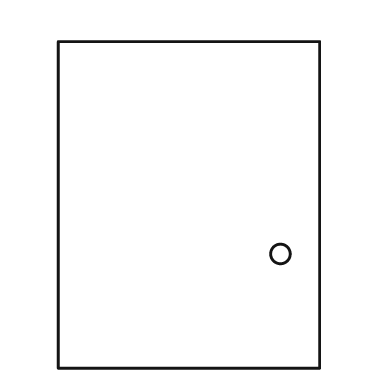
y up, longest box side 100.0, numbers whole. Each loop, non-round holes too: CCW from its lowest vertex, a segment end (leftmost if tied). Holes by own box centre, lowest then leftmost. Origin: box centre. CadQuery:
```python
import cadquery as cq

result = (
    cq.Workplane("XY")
    .moveTo(-40.0, -50.0)
    .lineTo(40.0, -50.0)
    .lineTo(40.0, 50.0)
    .lineTo(-40.0, 50.0)
    .close()
    .moveTo(28.0, -15.0)
    .circle(3.0)
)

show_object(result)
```